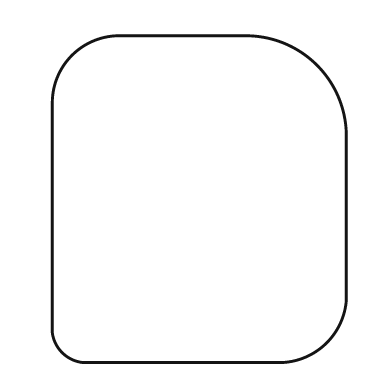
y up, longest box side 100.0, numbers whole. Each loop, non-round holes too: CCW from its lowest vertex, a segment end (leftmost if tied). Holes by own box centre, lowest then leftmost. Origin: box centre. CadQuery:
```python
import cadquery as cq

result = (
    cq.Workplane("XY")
    .moveTo(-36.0, -50.0)
    .lineTo(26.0, -50.0)
    .threePointArc((39.0, -44.0), (45.0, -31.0))
    .lineTo(45.0, 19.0)
    .threePointArc((36.0, 41.0), (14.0, 50.0))
    .lineTo(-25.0, 50.0)
    .threePointArc((-39.0, 44.0), (-45.0, 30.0))
    .lineTo(-45.0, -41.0)
    .threePointArc((-42.0, -47.0), (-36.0, -50.0))
    .close()
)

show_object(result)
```